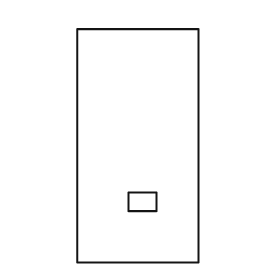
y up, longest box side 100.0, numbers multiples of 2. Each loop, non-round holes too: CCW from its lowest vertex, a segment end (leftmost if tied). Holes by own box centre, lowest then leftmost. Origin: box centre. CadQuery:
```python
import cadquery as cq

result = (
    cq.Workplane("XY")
    .moveTo(-26.0, -50.0)
    .lineTo(26.0, -50.0)
    .lineTo(26.0, 50.0)
    .lineTo(-26.0, 50.0)
    .close()
    .moveTo(-4.0, -28.0)
    .lineTo(8.0, -28.0)
    .lineTo(8.0, -20.0)
    .lineTo(-4.0, -20.0)
    .close()
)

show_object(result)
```